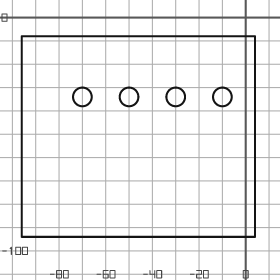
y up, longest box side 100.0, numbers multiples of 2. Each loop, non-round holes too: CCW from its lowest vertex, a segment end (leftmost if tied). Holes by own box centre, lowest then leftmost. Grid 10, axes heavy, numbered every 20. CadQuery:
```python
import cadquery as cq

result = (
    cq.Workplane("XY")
    .moveTo(-96.0, -94.0)
    .lineTo(4.0, -94.0)
    .lineTo(4.0, -8.0)
    .lineTo(-96.0, -8.0)
    .close()
    .moveTo(-70.0, -34.0)
    .circle(4.0)
    .moveTo(-50.0, -34.0)
    .circle(4.0)
    .moveTo(-30.0, -34.0)
    .circle(4.0)
    .moveTo(-10.0, -34.0)
    .circle(4.0)
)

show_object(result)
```